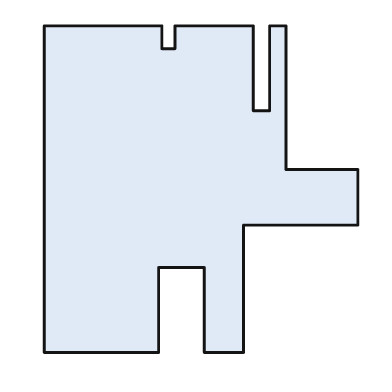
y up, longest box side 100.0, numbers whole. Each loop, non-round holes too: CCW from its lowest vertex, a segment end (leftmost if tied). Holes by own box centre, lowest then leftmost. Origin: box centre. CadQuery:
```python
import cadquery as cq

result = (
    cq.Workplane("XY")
    .moveTo(-48.0, -50.0)
    .lineTo(-13.0, -50.0)
    .lineTo(-13.0, -24.0)
    .lineTo(1.0, -24.0)
    .lineTo(1.0, -50.0)
    .lineTo(13.0, -50.0)
    .lineTo(13.0, -11.0)
    .lineTo(48.0, -11.0)
    .lineTo(48.0, 6.0)
    .lineTo(26.0, 6.0)
    .lineTo(26.0, 50.0)
    .lineTo(21.0, 50.0)
    .lineTo(21.0, 24.0)
    .lineTo(16.0, 24.0)
    .lineTo(16.0, 50.0)
    .lineTo(-8.0, 50.0)
    .lineTo(-8.0, 43.0)
    .lineTo(-12.0, 43.0)
    .lineTo(-12.0, 50.0)
    .lineTo(-48.0, 50.0)
    .close()
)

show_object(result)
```